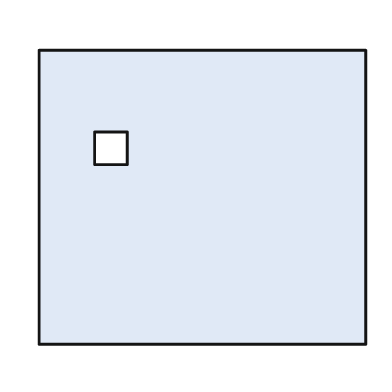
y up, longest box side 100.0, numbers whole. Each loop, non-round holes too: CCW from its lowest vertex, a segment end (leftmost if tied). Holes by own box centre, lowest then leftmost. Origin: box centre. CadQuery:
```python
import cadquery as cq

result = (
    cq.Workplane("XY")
    .moveTo(-50.0, -45.0)
    .lineTo(50.0, -45.0)
    .lineTo(50.0, 45.0)
    .lineTo(-50.0, 45.0)
    .close()
    .moveTo(-33.0, 10.0)
    .lineTo(-23.0, 10.0)
    .lineTo(-23.0, 20.0)
    .lineTo(-33.0, 20.0)
    .close()
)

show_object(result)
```